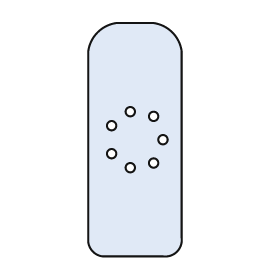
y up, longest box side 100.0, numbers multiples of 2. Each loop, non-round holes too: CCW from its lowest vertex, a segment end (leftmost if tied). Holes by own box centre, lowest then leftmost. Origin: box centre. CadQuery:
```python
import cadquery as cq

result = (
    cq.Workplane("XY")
    .moveTo(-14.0, -50.0)
    .lineTo(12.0, -50.0)
    .threePointArc((18.0, -48.0), (20.0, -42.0))
    .lineTo(20.0, 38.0)
    .threePointArc((16.0, 46.0), (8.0, 50.0))
    .lineTo(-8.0, 50.0)
    .threePointArc((-16.0, 46.0), (-20.0, 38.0))
    .lineTo(-20.0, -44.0)
    .threePointArc((-18.0, -48.0), (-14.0, -50.0))
    .close()
    .moveTo(-2.0, -12.0)
    .circle(2.0)
    .moveTo(8.0, -10.0)
    .circle(2.0)
    .moveTo(-10.0, -6.0)
    .circle(2.0)
    .moveTo(12.0, 0.0)
    .circle(2.0)
    .moveTo(-10.0, 6.0)
    .circle(2.0)
    .moveTo(8.0, 10.0)
    .circle(2.0)
    .moveTo(-2.0, 12.0)
    .circle(2.0)
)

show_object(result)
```